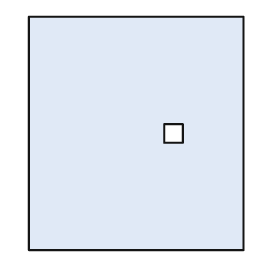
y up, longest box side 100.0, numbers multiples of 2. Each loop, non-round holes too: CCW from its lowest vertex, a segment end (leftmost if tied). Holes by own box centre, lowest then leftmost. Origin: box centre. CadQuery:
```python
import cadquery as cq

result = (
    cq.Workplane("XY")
    .moveTo(-46.0, -50.0)
    .lineTo(46.0, -50.0)
    .lineTo(46.0, 50.0)
    .lineTo(-46.0, 50.0)
    .close()
    .moveTo(12.0, -4.0)
    .lineTo(20.0, -4.0)
    .lineTo(20.0, 4.0)
    .lineTo(12.0, 4.0)
    .close()
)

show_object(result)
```